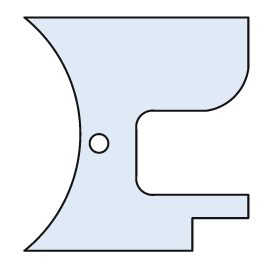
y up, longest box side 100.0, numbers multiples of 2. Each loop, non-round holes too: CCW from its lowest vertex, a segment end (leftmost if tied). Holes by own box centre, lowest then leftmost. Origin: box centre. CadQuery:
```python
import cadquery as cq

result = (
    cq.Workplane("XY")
    .moveTo(-48.0, -50.0)
    .lineTo(24.0, -50.0)
    .lineTo(24.0, -36.0)
    .lineTo(48.0, -36.0)
    .lineTo(48.0, -26.0)
    .lineTo(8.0, -26.0)
    .threePointArc((2.0, -24.0), (0.0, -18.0))
    .lineTo(0.0, 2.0)
    .threePointArc((2.0, 8.0), (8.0, 10.0))
    .lineTo(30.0, 10.0)
    .threePointArc((42.0, 16.0), (48.0, 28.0))
    .lineTo(48.0, 50.0)
    .lineTo(-48.0, 50.0)
    .threePointArc((-24.0, 0.0), (-48.0, -50.0))
    .close()
    .moveTo(-16.0, -4.0)
    .circle(4.0)
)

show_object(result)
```